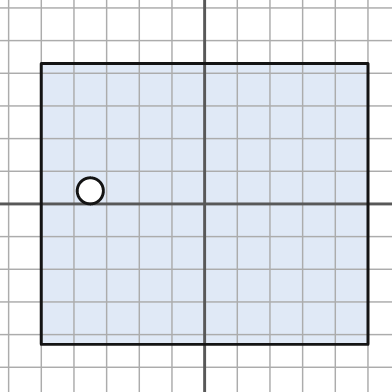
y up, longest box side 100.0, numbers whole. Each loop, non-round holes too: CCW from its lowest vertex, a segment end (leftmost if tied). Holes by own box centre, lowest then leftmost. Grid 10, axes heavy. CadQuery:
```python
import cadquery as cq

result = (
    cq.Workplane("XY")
    .moveTo(-50.0, -43.0)
    .lineTo(50.0, -43.0)
    .lineTo(50.0, 43.0)
    .lineTo(-50.0, 43.0)
    .close()
    .moveTo(-35.0, 4.0)
    .circle(4.0)
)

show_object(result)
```